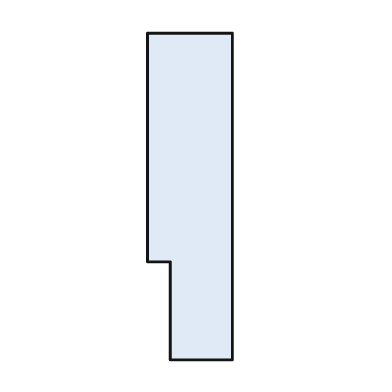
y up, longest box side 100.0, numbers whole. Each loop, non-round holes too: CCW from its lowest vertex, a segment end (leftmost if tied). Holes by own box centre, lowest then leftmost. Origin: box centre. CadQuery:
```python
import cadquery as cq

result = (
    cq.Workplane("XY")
    .moveTo(-6.0, -50.0)
    .lineTo(13.0, -50.0)
    .lineTo(13.0, 50.0)
    .lineTo(-13.0, 50.0)
    .lineTo(-13.0, -20.0)
    .lineTo(-6.0, -20.0)
    .close()
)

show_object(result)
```